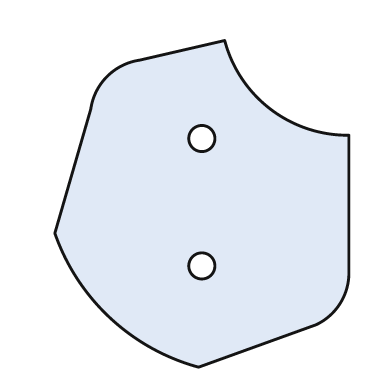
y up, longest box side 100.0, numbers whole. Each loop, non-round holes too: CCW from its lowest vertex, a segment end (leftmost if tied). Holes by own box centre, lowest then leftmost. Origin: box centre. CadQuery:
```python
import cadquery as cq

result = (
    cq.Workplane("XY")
    .moveTo(-1.0, -50.0)
    .lineTo(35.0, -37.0)
    .threePointArc((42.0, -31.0), (45.0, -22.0))
    .lineTo(45.0, 21.0)
    .threePointArc((21.0, 29.0), (7.0, 50.0))
    .lineTo(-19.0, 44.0)
    .threePointArc((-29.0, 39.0), (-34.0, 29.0))
    .lineTo(-45.0, -9.0)
    .threePointArc((-28.0, -35.0), (-1.0, -50.0))
    .close()
    .moveTo(0.0, -19.0)
    .circle(4.0)
    .moveTo(0.0, 20.0)
    .circle(4.0)
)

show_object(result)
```